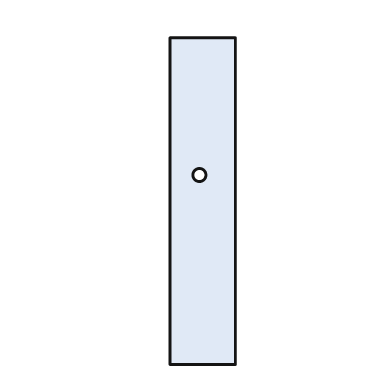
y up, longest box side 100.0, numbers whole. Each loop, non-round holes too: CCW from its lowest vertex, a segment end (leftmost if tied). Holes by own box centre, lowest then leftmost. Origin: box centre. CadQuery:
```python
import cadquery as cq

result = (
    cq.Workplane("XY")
    .moveTo(-10.0, -50.0)
    .lineTo(10.0, -50.0)
    .lineTo(10.0, 50.0)
    .lineTo(-10.0, 50.0)
    .close()
    .moveTo(-1.0, 8.0)
    .circle(2.0)
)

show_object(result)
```